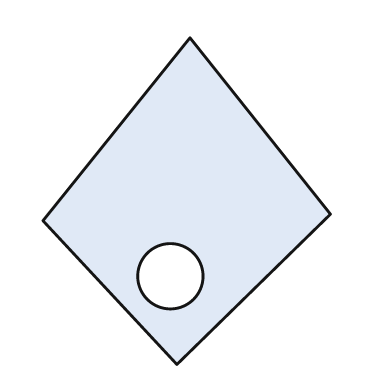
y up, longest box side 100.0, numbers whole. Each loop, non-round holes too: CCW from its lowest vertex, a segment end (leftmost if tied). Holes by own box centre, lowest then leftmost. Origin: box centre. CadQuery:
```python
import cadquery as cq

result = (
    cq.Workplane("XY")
    .moveTo(-3.0, -50.0)
    .lineTo(44.0, -4.0)
    .lineTo(1.0, 50.0)
    .lineTo(-44.0, -6.0)
    .close()
    .moveTo(-5.0, -23.0)
    .circle(10.0)
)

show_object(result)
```